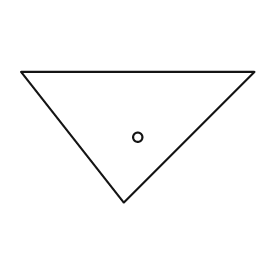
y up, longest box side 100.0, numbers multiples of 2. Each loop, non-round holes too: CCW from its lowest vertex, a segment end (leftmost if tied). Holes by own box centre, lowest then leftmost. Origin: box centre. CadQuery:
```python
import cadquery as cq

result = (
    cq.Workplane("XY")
    .moveTo(-6.0, -28.0)
    .lineTo(50.0, 28.0)
    .lineTo(-50.0, 28.0)
    .close()
    .moveTo(0.0, 0.0)
    .circle(2.0)
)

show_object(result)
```